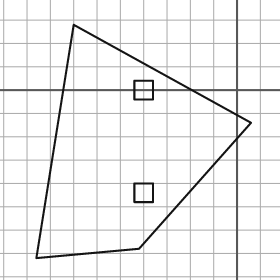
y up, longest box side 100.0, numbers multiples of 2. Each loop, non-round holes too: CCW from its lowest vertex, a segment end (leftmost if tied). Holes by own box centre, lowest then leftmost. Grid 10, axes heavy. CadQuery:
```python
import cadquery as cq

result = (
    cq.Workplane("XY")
    .moveTo(-86.0, -72.0)
    .lineTo(-42.0, -68.0)
    .lineTo(6.0, -14.0)
    .lineTo(-70.0, 28.0)
    .close()
    .moveTo(-44.0, -48.0)
    .lineTo(-36.0, -48.0)
    .lineTo(-36.0, -40.0)
    .lineTo(-44.0, -40.0)
    .close()
    .moveTo(-44.0, -4.0)
    .lineTo(-36.0, -4.0)
    .lineTo(-36.0, 4.0)
    .lineTo(-44.0, 4.0)
    .close()
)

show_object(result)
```